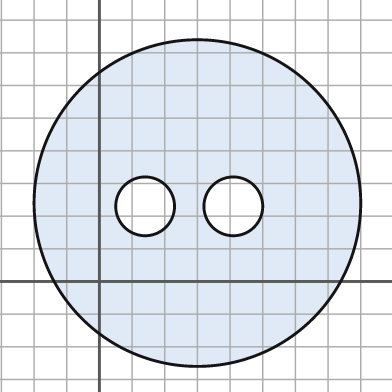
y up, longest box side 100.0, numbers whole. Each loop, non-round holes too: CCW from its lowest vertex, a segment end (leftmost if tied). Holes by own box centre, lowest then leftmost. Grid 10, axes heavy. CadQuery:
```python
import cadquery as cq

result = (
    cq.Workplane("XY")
    .moveTo(30.0, 24.0)
    .circle(50.0)
    .moveTo(14.0, 23.0)
    .circle(9.0)
    .moveTo(41.0, 23.0)
    .circle(9.0)
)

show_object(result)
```